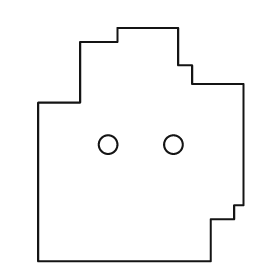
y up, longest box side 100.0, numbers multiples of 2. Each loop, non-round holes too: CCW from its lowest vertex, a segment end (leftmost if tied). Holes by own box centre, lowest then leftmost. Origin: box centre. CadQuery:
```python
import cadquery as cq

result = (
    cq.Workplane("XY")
    .moveTo(-44.0, -50.0)
    .lineTo(30.0, -50.0)
    .lineTo(30.0, -32.0)
    .lineTo(40.0, -32.0)
    .lineTo(40.0, -26.0)
    .lineTo(44.0, -26.0)
    .lineTo(44.0, 26.0)
    .lineTo(22.0, 26.0)
    .lineTo(22.0, 34.0)
    .lineTo(16.0, 34.0)
    .lineTo(16.0, 50.0)
    .lineTo(-10.0, 50.0)
    .lineTo(-10.0, 44.0)
    .lineTo(-26.0, 44.0)
    .lineTo(-26.0, 18.0)
    .lineTo(-44.0, 18.0)
    .close()
    .moveTo(-14.0, 0.0)
    .circle(4.0)
    .moveTo(14.0, 0.0)
    .circle(4.0)
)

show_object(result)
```